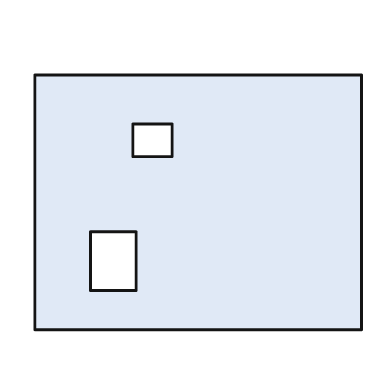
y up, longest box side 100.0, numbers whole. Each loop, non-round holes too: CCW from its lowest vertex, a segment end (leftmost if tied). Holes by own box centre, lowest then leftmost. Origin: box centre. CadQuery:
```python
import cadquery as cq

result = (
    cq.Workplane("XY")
    .moveTo(-50.0, -39.0)
    .lineTo(50.0, -39.0)
    .lineTo(50.0, 39.0)
    .lineTo(-50.0, 39.0)
    .close()
    .moveTo(-33.0, -27.0)
    .lineTo(-19.0, -27.0)
    .lineTo(-19.0, -9.0)
    .lineTo(-33.0, -9.0)
    .close()
    .moveTo(-20.0, 14.0)
    .lineTo(-8.0, 14.0)
    .lineTo(-8.0, 24.0)
    .lineTo(-20.0, 24.0)
    .close()
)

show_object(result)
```